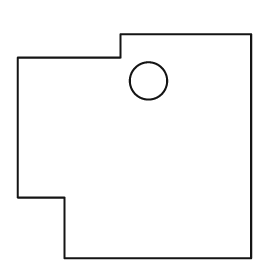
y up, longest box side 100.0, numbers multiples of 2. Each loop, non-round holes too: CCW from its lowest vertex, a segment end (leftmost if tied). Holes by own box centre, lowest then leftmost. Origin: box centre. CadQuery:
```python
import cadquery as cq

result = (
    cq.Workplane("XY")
    .moveTo(-30.0, -48.0)
    .lineTo(50.0, -48.0)
    .lineTo(50.0, 48.0)
    .lineTo(-6.0, 48.0)
    .lineTo(-6.0, 38.0)
    .lineTo(-50.0, 38.0)
    .lineTo(-50.0, -22.0)
    .lineTo(-30.0, -22.0)
    .close()
    .moveTo(6.0, 28.0)
    .circle(8.0)
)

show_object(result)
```